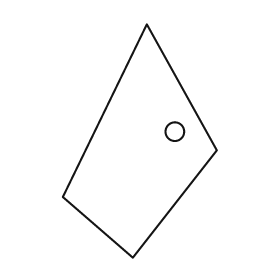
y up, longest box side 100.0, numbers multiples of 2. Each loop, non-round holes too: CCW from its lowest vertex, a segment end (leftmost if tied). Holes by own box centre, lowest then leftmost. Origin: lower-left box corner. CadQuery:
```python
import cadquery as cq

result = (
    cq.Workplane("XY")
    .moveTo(30.0, 0.0)
    .lineTo(66.0, 46.0)
    .lineTo(36.0, 100.0)
    .lineTo(0.0, 26.0)
    .close()
    .moveTo(48.0, 54.0)
    .circle(4.0)
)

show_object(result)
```